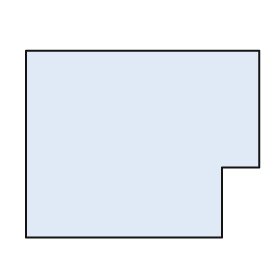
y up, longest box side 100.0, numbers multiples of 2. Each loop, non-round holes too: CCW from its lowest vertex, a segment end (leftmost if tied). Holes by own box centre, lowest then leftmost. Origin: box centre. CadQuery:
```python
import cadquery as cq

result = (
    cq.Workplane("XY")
    .moveTo(-50.0, -40.0)
    .lineTo(34.0, -40.0)
    .lineTo(34.0, -10.0)
    .lineTo(50.0, -10.0)
    .lineTo(50.0, 40.0)
    .lineTo(-50.0, 40.0)
    .close()
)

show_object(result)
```